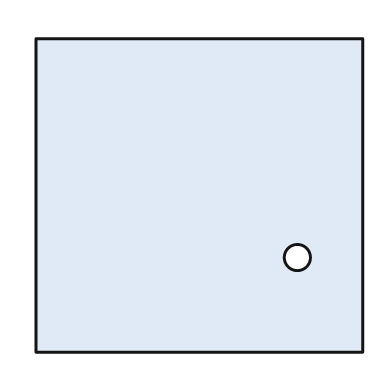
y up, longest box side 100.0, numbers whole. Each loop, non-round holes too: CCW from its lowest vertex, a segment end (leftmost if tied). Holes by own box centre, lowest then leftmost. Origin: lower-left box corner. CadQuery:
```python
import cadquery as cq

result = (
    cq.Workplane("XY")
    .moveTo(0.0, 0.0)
    .lineTo(100.0, 0.0)
    .lineTo(100.0, 96.0)
    .lineTo(0.0, 96.0)
    .close()
    .moveTo(80.0, 29.0)
    .circle(4.0)
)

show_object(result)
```